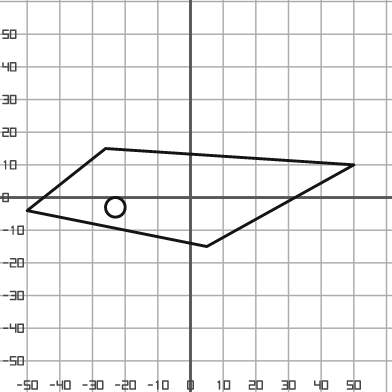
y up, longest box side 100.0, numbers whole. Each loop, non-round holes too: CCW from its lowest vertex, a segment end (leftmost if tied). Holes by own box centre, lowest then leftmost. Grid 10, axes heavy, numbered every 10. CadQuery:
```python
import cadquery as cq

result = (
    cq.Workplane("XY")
    .moveTo(5.0, -15.0)
    .lineTo(50.0, 10.0)
    .lineTo(-26.0, 15.0)
    .lineTo(-50.0, -4.0)
    .close()
    .moveTo(-23.0, -3.0)
    .circle(3.0)
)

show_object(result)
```